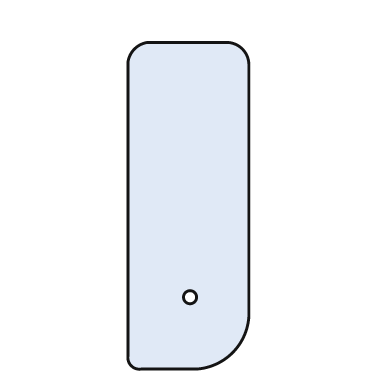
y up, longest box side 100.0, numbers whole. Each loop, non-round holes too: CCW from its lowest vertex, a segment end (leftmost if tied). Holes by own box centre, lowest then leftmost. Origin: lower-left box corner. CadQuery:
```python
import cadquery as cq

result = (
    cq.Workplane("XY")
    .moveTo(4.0, 0.0)
    .lineTo(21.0, 0.0)
    .threePointArc((32.0, 5.0), (37.0, 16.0))
    .lineTo(37.0, 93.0)
    .threePointArc((35.0, 98.0), (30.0, 100.0))
    .lineTo(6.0, 100.0)
    .threePointArc((2.0, 98.0), (0.0, 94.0))
    .lineTo(0.0, 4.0)
    .threePointArc((1.0, 1.0), (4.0, 0.0))
    .close()
    .moveTo(19.0, 22.0)
    .circle(2.0)
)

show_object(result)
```